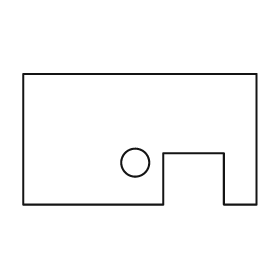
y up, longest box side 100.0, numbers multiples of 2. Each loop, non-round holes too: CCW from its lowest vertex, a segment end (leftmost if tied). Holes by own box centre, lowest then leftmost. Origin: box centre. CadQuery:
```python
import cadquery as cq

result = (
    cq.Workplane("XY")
    .moveTo(-50.0, -28.0)
    .lineTo(10.0, -28.0)
    .lineTo(10.0, -6.0)
    .lineTo(36.0, -6.0)
    .lineTo(36.0, -28.0)
    .lineTo(50.0, -28.0)
    .lineTo(50.0, 28.0)
    .lineTo(-50.0, 28.0)
    .close()
    .moveTo(-2.0, -10.0)
    .circle(6.0)
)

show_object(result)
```